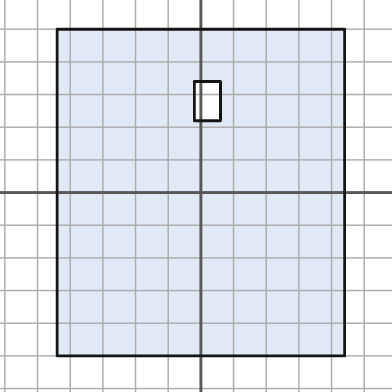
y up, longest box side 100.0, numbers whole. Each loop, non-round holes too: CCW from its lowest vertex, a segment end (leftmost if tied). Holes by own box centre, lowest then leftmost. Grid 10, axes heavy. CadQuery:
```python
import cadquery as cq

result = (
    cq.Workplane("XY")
    .moveTo(-44.0, -50.0)
    .lineTo(44.0, -50.0)
    .lineTo(44.0, 50.0)
    .lineTo(-44.0, 50.0)
    .close()
    .moveTo(-2.0, 22.0)
    .lineTo(6.0, 22.0)
    .lineTo(6.0, 34.0)
    .lineTo(-2.0, 34.0)
    .close()
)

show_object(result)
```